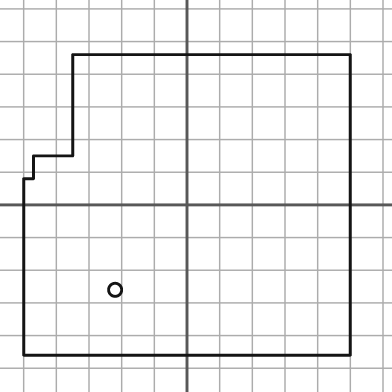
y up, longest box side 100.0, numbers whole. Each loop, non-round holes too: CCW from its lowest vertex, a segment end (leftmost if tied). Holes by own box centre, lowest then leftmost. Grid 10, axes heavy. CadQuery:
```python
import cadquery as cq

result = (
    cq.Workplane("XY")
    .moveTo(-50.0, -46.0)
    .lineTo(50.0, -46.0)
    .lineTo(50.0, 46.0)
    .lineTo(-35.0, 46.0)
    .lineTo(-35.0, 15.0)
    .lineTo(-47.0, 15.0)
    .lineTo(-47.0, 8.0)
    .lineTo(-50.0, 8.0)
    .close()
    .moveTo(-22.0, -26.0)
    .circle(2.0)
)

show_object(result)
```